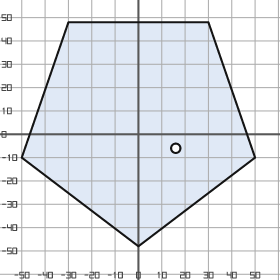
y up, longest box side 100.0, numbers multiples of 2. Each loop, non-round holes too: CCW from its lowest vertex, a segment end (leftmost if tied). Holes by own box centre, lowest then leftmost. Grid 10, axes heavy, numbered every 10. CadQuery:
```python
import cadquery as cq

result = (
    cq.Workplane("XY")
    .moveTo(0.0, -48.0)
    .lineTo(50.0, -10.0)
    .lineTo(30.0, 48.0)
    .lineTo(-30.0, 48.0)
    .lineTo(-50.0, -10.0)
    .close()
    .moveTo(16.0, -6.0)
    .circle(2.0)
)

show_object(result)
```